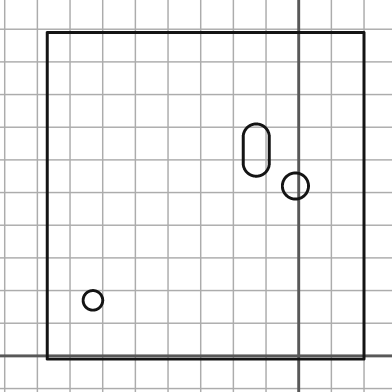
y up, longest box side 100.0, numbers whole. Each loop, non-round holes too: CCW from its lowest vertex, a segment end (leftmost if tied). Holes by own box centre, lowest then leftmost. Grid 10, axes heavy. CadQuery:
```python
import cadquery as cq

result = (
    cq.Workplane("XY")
    .moveTo(-77.0, -1.0)
    .lineTo(20.0, -1.0)
    .lineTo(20.0, 99.0)
    .lineTo(-77.0, 99.0)
    .close()
    .moveTo(-63.0, 17.0)
    .circle(3.0)
    .moveTo(-1.0, 52.0)
    .circle(4.0)
    .moveTo(-17.0, 59.0)
    .threePointArc((-13.0, 55.0), (-9.0, 59.0))
    .lineTo(-9.0, 67.0)
    .threePointArc((-13.0, 71.0), (-17.0, 67.0))
    .close()
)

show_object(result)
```